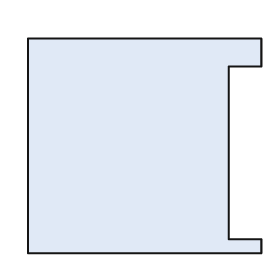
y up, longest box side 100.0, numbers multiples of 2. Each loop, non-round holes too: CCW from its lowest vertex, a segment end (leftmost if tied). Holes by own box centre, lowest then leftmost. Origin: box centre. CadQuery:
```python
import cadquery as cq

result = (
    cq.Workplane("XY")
    .moveTo(-50.0, -46.0)
    .lineTo(50.0, -46.0)
    .lineTo(50.0, -40.0)
    .lineTo(36.0, -40.0)
    .lineTo(36.0, 34.0)
    .lineTo(50.0, 34.0)
    .lineTo(50.0, 46.0)
    .lineTo(-50.0, 46.0)
    .close()
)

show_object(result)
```